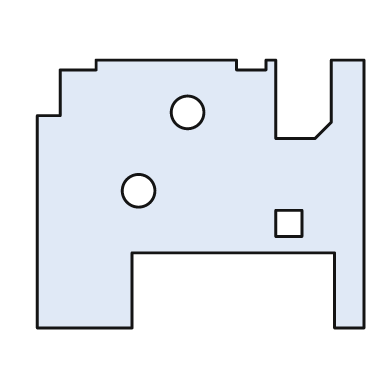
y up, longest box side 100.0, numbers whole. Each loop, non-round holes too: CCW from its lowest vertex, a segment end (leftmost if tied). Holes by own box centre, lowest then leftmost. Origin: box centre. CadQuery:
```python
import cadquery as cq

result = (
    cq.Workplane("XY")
    .moveTo(-50.0, -41.0)
    .lineTo(-21.0, -41.0)
    .lineTo(-21.0, -18.0)
    .lineTo(41.0, -18.0)
    .lineTo(41.0, -41.0)
    .lineTo(50.0, -41.0)
    .lineTo(50.0, 41.0)
    .lineTo(40.0, 41.0)
    .lineTo(40.0, 22.0)
    .lineTo(35.0, 17.0)
    .lineTo(23.0, 17.0)
    .lineTo(23.0, 41.0)
    .lineTo(20.0, 41.0)
    .lineTo(20.0, 38.0)
    .lineTo(11.0, 38.0)
    .lineTo(11.0, 41.0)
    .lineTo(-32.0, 41.0)
    .lineTo(-32.0, 38.0)
    .lineTo(-43.0, 38.0)
    .lineTo(-43.0, 24.0)
    .lineTo(-50.0, 24.0)
    .close()
    .moveTo(23.0, -13.0)
    .lineTo(31.0, -13.0)
    .lineTo(31.0, -5.0)
    .lineTo(23.0, -5.0)
    .close()
    .moveTo(-19.0, 1.0)
    .circle(5.0)
    .moveTo(-4.0, 25.0)
    .circle(5.0)
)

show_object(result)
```